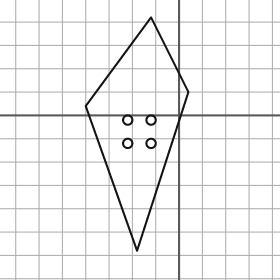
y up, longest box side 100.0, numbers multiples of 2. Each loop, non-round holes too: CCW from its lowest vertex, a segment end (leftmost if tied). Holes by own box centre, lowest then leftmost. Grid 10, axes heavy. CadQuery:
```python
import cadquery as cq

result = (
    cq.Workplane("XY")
    .moveTo(-18.0, -58.0)
    .lineTo(4.0, 10.0)
    .lineTo(-12.0, 42.0)
    .lineTo(-40.0, 4.0)
    .close()
    .moveTo(-22.0, -12.0)
    .circle(2.0)
    .moveTo(-12.0, -12.0)
    .circle(2.0)
    .moveTo(-22.0, -2.0)
    .circle(2.0)
    .moveTo(-12.0, -2.0)
    .circle(2.0)
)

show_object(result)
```